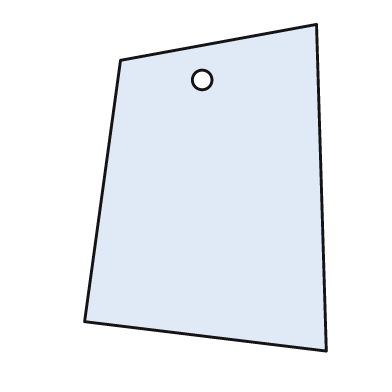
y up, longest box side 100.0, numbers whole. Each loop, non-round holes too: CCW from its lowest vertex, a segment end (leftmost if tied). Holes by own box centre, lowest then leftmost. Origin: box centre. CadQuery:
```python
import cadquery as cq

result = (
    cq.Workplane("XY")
    .moveTo(37.0, -50.0)
    .lineTo(34.0, 50.0)
    .lineTo(-26.0, 39.0)
    .lineTo(-37.0, -41.0)
    .close()
    .moveTo(-1.0, 33.0)
    .circle(3.0)
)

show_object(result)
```